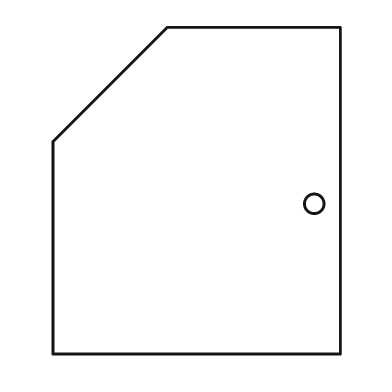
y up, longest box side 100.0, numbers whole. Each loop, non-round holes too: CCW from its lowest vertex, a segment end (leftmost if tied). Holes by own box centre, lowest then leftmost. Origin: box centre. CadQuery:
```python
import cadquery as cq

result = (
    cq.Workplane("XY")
    .moveTo(-44.0, -50.0)
    .lineTo(44.0, -50.0)
    .lineTo(44.0, 50.0)
    .lineTo(-9.0, 50.0)
    .lineTo(-44.0, 15.0)
    .close()
    .moveTo(36.0, -4.0)
    .circle(3.0)
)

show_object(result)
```